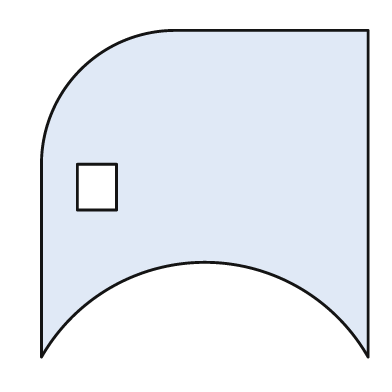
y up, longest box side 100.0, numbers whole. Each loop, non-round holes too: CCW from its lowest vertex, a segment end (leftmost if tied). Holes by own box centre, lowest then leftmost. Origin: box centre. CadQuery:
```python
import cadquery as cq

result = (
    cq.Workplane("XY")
    .moveTo(-50.0, -50.0)
    .threePointArc((0.0, -21.0), (50.0, -50.0))
    .lineTo(50.0, 50.0)
    .lineTo(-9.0, 50.0)
    .threePointArc((-38.0, 38.0), (-50.0, 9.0))
    .close()
    .moveTo(-39.0, -5.0)
    .lineTo(-27.0, -5.0)
    .lineTo(-27.0, 9.0)
    .lineTo(-39.0, 9.0)
    .close()
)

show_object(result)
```